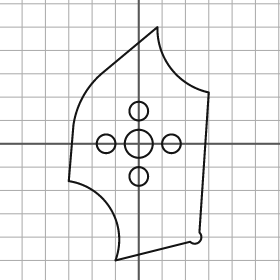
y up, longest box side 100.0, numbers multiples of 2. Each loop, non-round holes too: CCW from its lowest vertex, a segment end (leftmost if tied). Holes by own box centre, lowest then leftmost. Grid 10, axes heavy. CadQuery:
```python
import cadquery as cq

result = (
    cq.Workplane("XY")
    .moveTo(-10.0, -50.0)
    .lineTo(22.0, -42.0)
    .threePointArc((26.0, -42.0), (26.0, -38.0))
    .lineTo(30.0, 22.0)
    .threePointArc((14.0, 32.0), (8.0, 50.0))
    .lineTo(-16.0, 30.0)
    .threePointArc((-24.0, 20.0), (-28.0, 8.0))
    .lineTo(-30.0, -16.0)
    .threePointArc((-12.0, -28.0), (-10.0, -50.0))
    .close()
    .moveTo(0.0, -14.0)
    .circle(4.0)
    .moveTo(-14.0, 0.0)
    .circle(4.0)
    .moveTo(0.0, 0.0)
    .circle(6.0)
    .moveTo(14.0, 0.0)
    .circle(4.0)
    .moveTo(0.0, 14.0)
    .circle(4.0)
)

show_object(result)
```